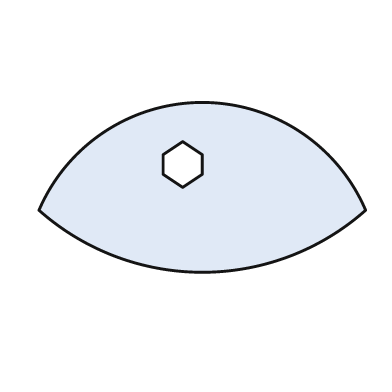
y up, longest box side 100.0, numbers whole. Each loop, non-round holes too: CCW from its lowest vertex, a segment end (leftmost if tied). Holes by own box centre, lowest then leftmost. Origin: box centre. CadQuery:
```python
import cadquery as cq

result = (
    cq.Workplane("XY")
    .moveTo(-50.0, -7.0)
    .threePointArc((0.0, -26.0), (50.0, -7.0))
    .threePointArc((0.0, 26.0), (-50.0, -7.0))
    .close()
    .moveTo(-6.0, 0.0)
    .lineTo(0.0, 4.0)
    .lineTo(0.0, 10.0)
    .lineTo(-6.0, 14.0)
    .lineTo(-12.0, 10.0)
    .lineTo(-12.0, 4.0)
    .close()
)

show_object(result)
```